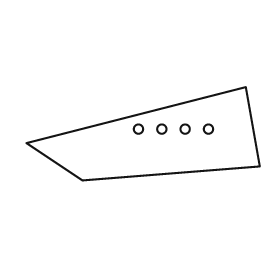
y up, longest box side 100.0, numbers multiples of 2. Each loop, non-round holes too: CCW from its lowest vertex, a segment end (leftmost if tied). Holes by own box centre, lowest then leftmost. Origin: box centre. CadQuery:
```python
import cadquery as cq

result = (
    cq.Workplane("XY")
    .moveTo(-26.0, -20.0)
    .lineTo(50.0, -14.0)
    .lineTo(44.0, 20.0)
    .lineTo(-50.0, -4.0)
    .close()
    .moveTo(-2.0, 2.0)
    .circle(2.0)
    .moveTo(8.0, 2.0)
    .circle(2.0)
    .moveTo(18.0, 2.0)
    .circle(2.0)
    .moveTo(28.0, 2.0)
    .circle(2.0)
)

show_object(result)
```